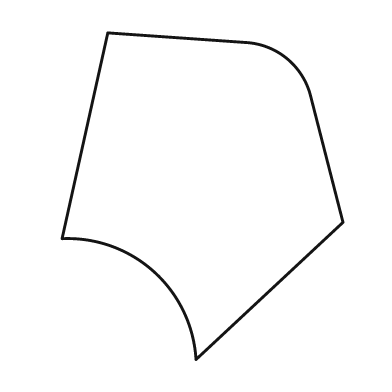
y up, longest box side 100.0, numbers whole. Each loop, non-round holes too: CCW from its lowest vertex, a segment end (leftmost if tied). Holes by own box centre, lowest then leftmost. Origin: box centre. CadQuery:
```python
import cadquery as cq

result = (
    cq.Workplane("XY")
    .moveTo(-2.0, -50.0)
    .lineTo(43.0, -8.0)
    .lineTo(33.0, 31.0)
    .threePointArc((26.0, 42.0), (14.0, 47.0))
    .lineTo(-29.0, 50.0)
    .lineTo(-43.0, -13.0)
    .threePointArc((-15.0, -23.0), (-2.0, -50.0))
    .close()
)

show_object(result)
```